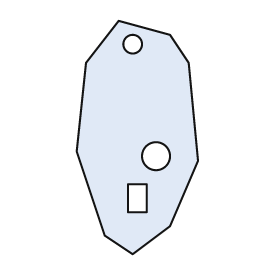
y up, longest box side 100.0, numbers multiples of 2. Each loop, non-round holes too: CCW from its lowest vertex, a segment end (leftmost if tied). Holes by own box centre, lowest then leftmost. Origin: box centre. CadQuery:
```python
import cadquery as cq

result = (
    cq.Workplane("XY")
    .moveTo(-2.0, -50.0)
    .lineTo(14.0, -38.0)
    .lineTo(26.0, -10.0)
    .lineTo(22.0, 32.0)
    .lineTo(14.0, 44.0)
    .lineTo(-8.0, 50.0)
    .lineTo(-22.0, 32.0)
    .lineTo(-26.0, -6.0)
    .lineTo(-14.0, -42.0)
    .close()
    .moveTo(-4.0, -32.0)
    .lineTo(4.0, -32.0)
    .lineTo(4.0, -20.0)
    .lineTo(-4.0, -20.0)
    .close()
    .moveTo(8.0, -8.0)
    .circle(6.0)
    .moveTo(-2.0, 40.0)
    .circle(4.0)
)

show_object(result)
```